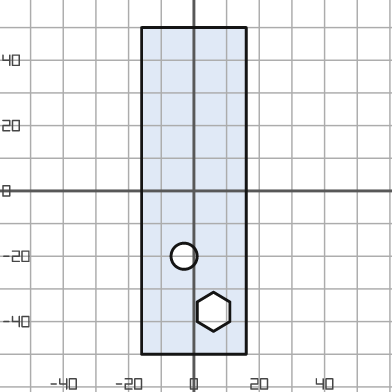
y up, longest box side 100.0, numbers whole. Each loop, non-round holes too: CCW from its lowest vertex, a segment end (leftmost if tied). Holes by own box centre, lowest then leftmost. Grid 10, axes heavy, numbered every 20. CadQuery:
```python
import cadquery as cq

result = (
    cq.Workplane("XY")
    .moveTo(-16.0, -50.0)
    .lineTo(16.0, -50.0)
    .lineTo(16.0, 50.0)
    .lineTo(-16.0, 50.0)
    .close()
    .moveTo(6.0, -43.0)
    .lineTo(11.0, -40.0)
    .lineTo(11.0, -34.0)
    .lineTo(6.0, -31.0)
    .lineTo(1.0, -34.0)
    .lineTo(1.0, -40.0)
    .close()
    .moveTo(-3.0, -20.0)
    .circle(4.0)
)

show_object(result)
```